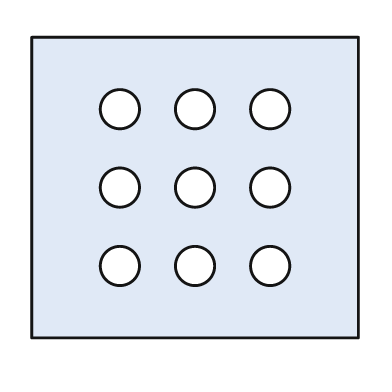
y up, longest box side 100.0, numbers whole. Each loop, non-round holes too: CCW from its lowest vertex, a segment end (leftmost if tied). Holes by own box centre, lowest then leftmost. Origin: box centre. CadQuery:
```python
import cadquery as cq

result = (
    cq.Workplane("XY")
    .moveTo(-50.0, -46.0)
    .lineTo(50.0, -46.0)
    .lineTo(50.0, 46.0)
    .lineTo(-50.0, 46.0)
    .close()
    .moveTo(-23.0, -24.0)
    .circle(6.0)
    .moveTo(0.0, -24.0)
    .circle(6.0)
    .moveTo(23.0, -24.0)
    .circle(6.0)
    .moveTo(-23.0, 0.0)
    .circle(6.0)
    .moveTo(0.0, 0.0)
    .circle(6.0)
    .moveTo(23.0, 0.0)
    .circle(6.0)
    .moveTo(-23.0, 24.0)
    .circle(6.0)
    .moveTo(0.0, 24.0)
    .circle(6.0)
    .moveTo(23.0, 24.0)
    .circle(6.0)
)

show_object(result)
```